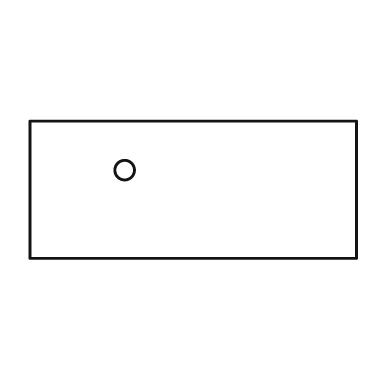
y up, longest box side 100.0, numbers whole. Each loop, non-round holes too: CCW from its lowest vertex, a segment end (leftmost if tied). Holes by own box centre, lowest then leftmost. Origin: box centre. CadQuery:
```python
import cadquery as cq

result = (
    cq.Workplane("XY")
    .moveTo(-50.0, -21.0)
    .lineTo(50.0, -21.0)
    .lineTo(50.0, 21.0)
    .lineTo(-50.0, 21.0)
    .close()
    .moveTo(-21.0, 6.0)
    .circle(3.0)
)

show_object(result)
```